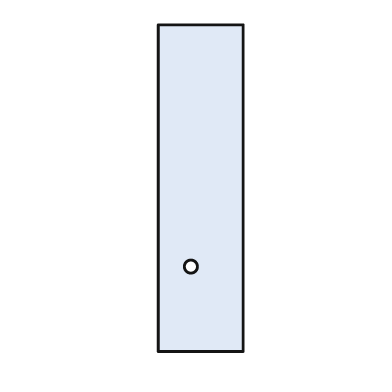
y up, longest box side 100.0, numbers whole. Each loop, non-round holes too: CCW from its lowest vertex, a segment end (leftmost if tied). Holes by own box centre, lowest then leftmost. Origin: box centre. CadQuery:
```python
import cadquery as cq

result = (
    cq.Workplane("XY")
    .moveTo(-13.0, -50.0)
    .lineTo(13.0, -50.0)
    .lineTo(13.0, 50.0)
    .lineTo(-13.0, 50.0)
    .close()
    .moveTo(-3.0, -24.0)
    .circle(2.0)
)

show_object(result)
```